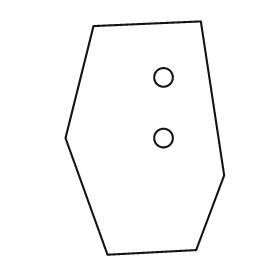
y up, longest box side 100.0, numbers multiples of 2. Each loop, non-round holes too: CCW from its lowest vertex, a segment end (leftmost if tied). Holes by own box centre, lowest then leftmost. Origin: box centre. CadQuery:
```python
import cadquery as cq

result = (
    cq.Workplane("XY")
    .moveTo(-16.0, -50.0)
    .lineTo(22.0, -48.0)
    .lineTo(34.0, -16.0)
    .lineTo(24.0, 50.0)
    .lineTo(-22.0, 48.0)
    .lineTo(-34.0, 0.0)
    .close()
    .moveTo(8.0, 0.0)
    .circle(4.0)
    .moveTo(8.0, 26.0)
    .circle(4.0)
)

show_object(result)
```